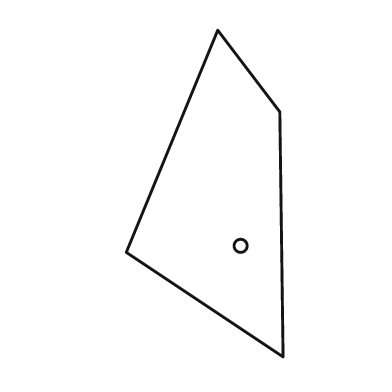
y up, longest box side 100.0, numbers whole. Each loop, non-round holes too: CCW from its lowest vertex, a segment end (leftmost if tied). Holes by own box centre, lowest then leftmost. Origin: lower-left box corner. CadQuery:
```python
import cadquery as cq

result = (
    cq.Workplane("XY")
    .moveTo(48.0, 0.0)
    .lineTo(47.0, 75.0)
    .lineTo(28.0, 100.0)
    .lineTo(0.0, 32.0)
    .close()
    .moveTo(35.0, 34.0)
    .circle(2.0)
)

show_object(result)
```